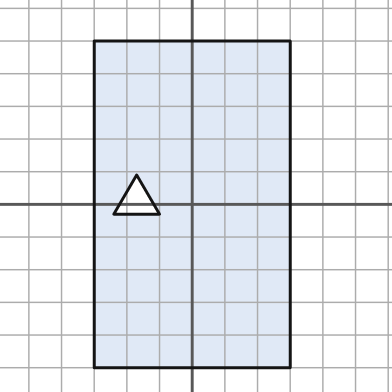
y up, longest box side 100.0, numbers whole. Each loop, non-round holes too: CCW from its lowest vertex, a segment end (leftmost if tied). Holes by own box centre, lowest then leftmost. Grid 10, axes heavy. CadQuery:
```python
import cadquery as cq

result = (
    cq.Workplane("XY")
    .moveTo(-30.0, -50.0)
    .lineTo(30.0, -50.0)
    .lineTo(30.0, 50.0)
    .lineTo(-30.0, 50.0)
    .close()
    .moveTo(-24.0, -3.0)
    .lineTo(-10.0, -3.0)
    .lineTo(-17.0, 9.0)
    .close()
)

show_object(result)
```